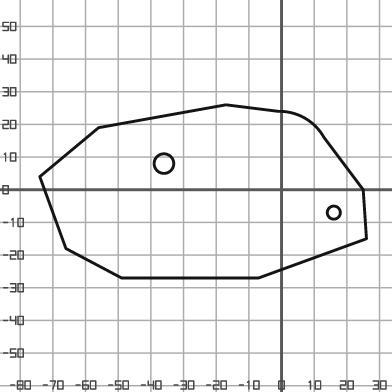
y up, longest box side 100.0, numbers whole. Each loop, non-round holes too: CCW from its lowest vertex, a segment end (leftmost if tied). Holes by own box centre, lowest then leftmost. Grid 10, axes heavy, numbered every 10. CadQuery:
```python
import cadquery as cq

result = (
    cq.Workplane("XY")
    .moveTo(-49.0, -27.0)
    .lineTo(-7.0, -27.0)
    .lineTo(26.0, -15.0)
    .lineTo(25.0, 0.0)
    .lineTo(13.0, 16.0)
    .threePointArc((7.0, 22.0), (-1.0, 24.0))
    .lineTo(-17.0, 26.0)
    .lineTo(-56.0, 19.0)
    .lineTo(-74.0, 4.0)
    .lineTo(-66.0, -18.0)
    .close()
    .moveTo(16.0, -7.0)
    .circle(2.0)
    .moveTo(-36.0, 8.0)
    .circle(3.0)
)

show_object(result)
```